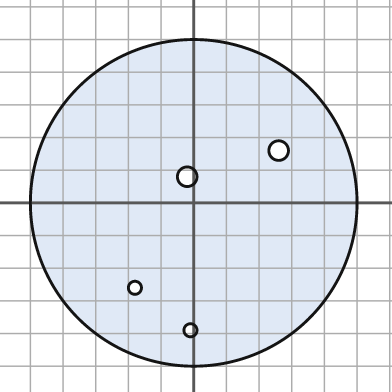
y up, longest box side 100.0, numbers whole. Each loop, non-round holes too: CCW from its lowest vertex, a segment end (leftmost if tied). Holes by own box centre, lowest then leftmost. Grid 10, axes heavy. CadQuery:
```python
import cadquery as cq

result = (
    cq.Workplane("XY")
    .moveTo(0.0, 0.0)
    .circle(50.0)
    .moveTo(-1.0, -39.0)
    .circle(2.0)
    .moveTo(-18.0, -26.0)
    .circle(2.0)
    .moveTo(-2.0, 8.0)
    .circle(3.0)
    .moveTo(26.0, 16.0)
    .circle(3.0)
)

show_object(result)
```